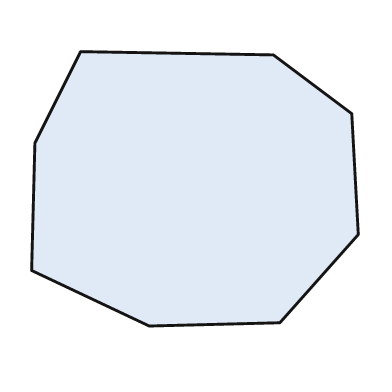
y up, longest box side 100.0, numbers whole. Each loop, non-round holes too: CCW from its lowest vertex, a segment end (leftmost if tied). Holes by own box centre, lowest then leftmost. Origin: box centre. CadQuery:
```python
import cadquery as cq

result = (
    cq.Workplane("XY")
    .moveTo(-14.0, -42.0)
    .lineTo(26.0, -41.0)
    .lineTo(50.0, -14.0)
    .lineTo(48.0, 23.0)
    .lineTo(24.0, 41.0)
    .lineTo(-35.0, 42.0)
    .lineTo(-49.0, 14.0)
    .lineTo(-50.0, -25.0)
    .close()
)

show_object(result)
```